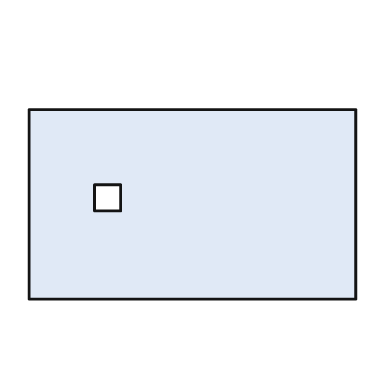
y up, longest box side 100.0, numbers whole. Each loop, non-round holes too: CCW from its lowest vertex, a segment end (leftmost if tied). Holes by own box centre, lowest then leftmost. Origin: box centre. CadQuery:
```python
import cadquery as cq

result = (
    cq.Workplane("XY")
    .moveTo(-50.0, -29.0)
    .lineTo(50.0, -29.0)
    .lineTo(50.0, 29.0)
    .lineTo(-50.0, 29.0)
    .close()
    .moveTo(-30.0, -2.0)
    .lineTo(-22.0, -2.0)
    .lineTo(-22.0, 6.0)
    .lineTo(-30.0, 6.0)
    .close()
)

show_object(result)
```